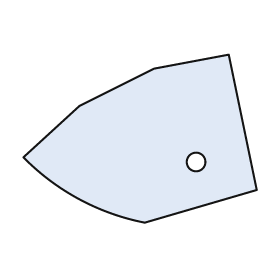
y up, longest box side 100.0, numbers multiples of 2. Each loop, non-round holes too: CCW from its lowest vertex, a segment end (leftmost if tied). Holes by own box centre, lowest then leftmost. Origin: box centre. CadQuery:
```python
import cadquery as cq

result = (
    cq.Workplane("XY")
    .moveTo(2.0, -36.0)
    .lineTo(50.0, -22.0)
    .lineTo(38.0, 36.0)
    .lineTo(6.0, 30.0)
    .lineTo(-26.0, 14.0)
    .lineTo(-50.0, -8.0)
    .threePointArc((-26.0, -26.0), (2.0, -36.0))
    .close()
    .moveTo(24.0, -10.0)
    .circle(4.0)
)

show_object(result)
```